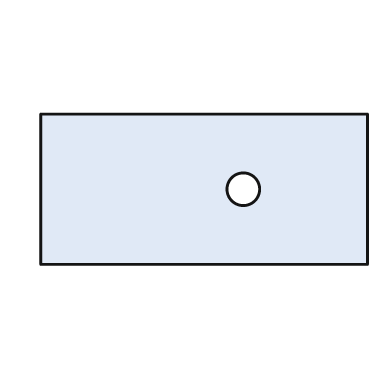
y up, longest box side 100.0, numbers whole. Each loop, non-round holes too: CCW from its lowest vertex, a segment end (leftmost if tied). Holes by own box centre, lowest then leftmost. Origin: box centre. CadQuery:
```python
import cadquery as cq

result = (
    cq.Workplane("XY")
    .moveTo(-50.0, -23.0)
    .lineTo(50.0, -23.0)
    .lineTo(50.0, 23.0)
    .lineTo(-50.0, 23.0)
    .close()
    .moveTo(12.0, 0.0)
    .circle(5.0)
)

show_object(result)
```